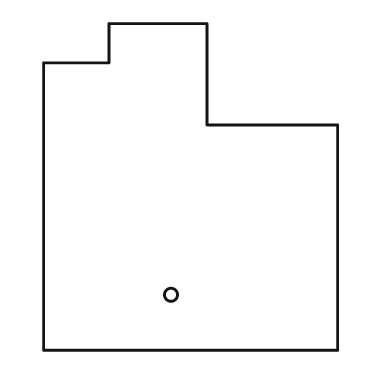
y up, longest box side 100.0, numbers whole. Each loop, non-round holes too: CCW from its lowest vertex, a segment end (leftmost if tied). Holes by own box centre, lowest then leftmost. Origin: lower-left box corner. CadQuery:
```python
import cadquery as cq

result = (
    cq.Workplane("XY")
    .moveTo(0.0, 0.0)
    .lineTo(90.0, 0.0)
    .lineTo(90.0, 69.0)
    .lineTo(50.0, 69.0)
    .lineTo(50.0, 100.0)
    .lineTo(20.0, 100.0)
    .lineTo(20.0, 88.0)
    .lineTo(0.0, 88.0)
    .close()
    .moveTo(39.0, 17.0)
    .circle(2.0)
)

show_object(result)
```